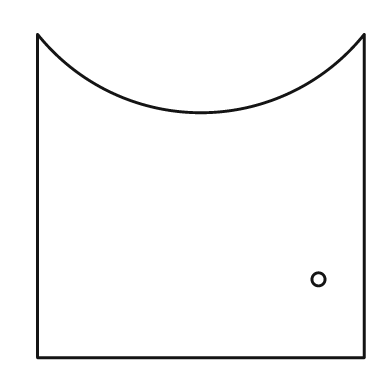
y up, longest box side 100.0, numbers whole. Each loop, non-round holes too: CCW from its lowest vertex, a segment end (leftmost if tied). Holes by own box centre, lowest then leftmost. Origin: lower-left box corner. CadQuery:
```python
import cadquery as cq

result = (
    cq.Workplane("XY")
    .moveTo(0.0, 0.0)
    .lineTo(100.0, 0.0)
    .lineTo(100.0, 99.0)
    .threePointArc((50.0, 75.0), (0.0, 99.0))
    .close()
    .moveTo(86.0, 24.0)
    .circle(2.0)
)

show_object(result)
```